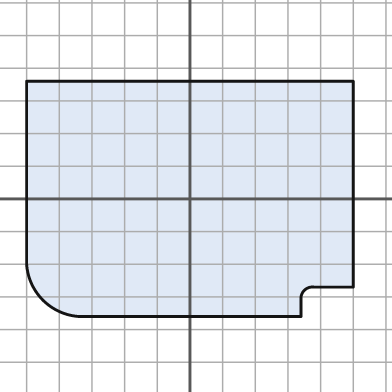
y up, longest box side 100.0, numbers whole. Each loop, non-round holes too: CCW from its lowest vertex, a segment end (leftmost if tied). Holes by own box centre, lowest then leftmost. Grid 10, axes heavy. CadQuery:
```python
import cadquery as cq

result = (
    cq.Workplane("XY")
    .moveTo(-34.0, -36.0)
    .lineTo(34.0, -36.0)
    .lineTo(34.0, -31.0)
    .threePointArc((35.0, -28.0), (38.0, -27.0))
    .lineTo(50.0, -27.0)
    .lineTo(50.0, 36.0)
    .lineTo(-50.0, 36.0)
    .lineTo(-50.0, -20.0)
    .threePointArc((-45.0, -31.0), (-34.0, -36.0))
    .close()
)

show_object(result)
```